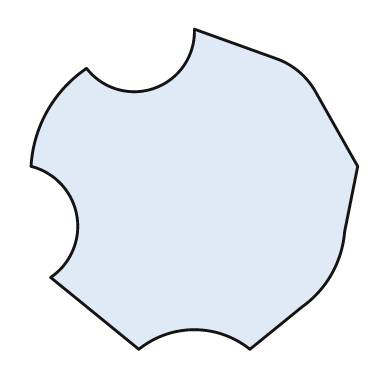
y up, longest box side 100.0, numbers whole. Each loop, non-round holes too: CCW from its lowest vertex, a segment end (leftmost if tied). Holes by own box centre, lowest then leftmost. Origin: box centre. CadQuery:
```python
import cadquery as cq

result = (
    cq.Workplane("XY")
    .moveTo(-17.0, -49.0)
    .threePointArc((0.0, -43.0), (17.0, -49.0))
    .lineTo(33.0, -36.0)
    .threePointArc((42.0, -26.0), (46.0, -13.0))
    .lineTo(50.0, 7.0)
    .lineTo(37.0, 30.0)
    .threePointArc((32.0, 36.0), (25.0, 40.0))
    .lineTo(0.0, 49.0)
    .threePointArc((-12.0, 31.0), (-33.0, 37.0))
    .threePointArc((-45.0, 24.0), (-50.0, 7.0))
    .threePointArc((-36.0, -8.0), (-44.0, -27.0))
    .close()
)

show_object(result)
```